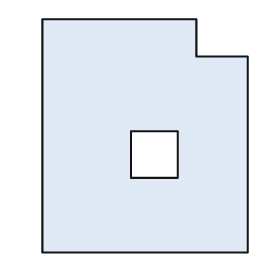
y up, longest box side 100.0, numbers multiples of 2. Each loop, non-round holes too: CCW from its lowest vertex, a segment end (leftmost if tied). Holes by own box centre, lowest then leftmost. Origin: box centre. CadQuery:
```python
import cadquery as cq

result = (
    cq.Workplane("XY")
    .moveTo(-44.0, -50.0)
    .lineTo(44.0, -50.0)
    .lineTo(44.0, 34.0)
    .lineTo(22.0, 34.0)
    .lineTo(22.0, 50.0)
    .lineTo(-44.0, 50.0)
    .close()
    .moveTo(-6.0, -18.0)
    .lineTo(14.0, -18.0)
    .lineTo(14.0, 2.0)
    .lineTo(-6.0, 2.0)
    .close()
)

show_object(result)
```